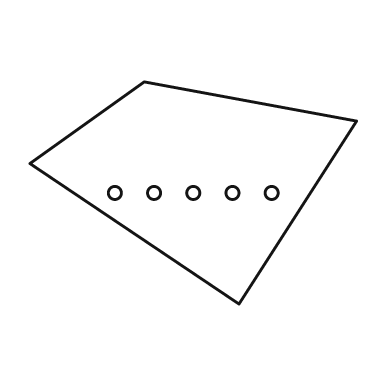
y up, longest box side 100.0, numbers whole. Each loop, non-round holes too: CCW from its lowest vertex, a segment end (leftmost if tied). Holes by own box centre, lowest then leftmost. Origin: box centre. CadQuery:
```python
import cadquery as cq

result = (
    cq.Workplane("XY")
    .moveTo(14.0, -34.0)
    .lineTo(50.0, 22.0)
    .lineTo(-15.0, 34.0)
    .lineTo(-50.0, 9.0)
    .close()
    .moveTo(-24.0, 0.0)
    .circle(2.0)
    .moveTo(-12.0, 0.0)
    .circle(2.0)
    .moveTo(0.0, 0.0)
    .circle(2.0)
    .moveTo(12.0, 0.0)
    .circle(2.0)
    .moveTo(24.0, 0.0)
    .circle(2.0)
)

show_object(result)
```